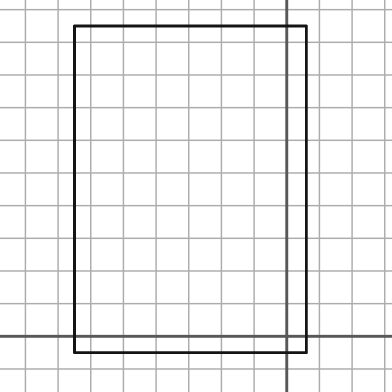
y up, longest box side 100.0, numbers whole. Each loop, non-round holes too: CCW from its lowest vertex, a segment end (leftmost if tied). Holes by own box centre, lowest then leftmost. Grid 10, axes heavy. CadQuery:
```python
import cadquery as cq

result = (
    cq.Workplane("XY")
    .moveTo(-65.0, -5.0)
    .lineTo(6.0, -5.0)
    .lineTo(6.0, 95.0)
    .lineTo(-65.0, 95.0)
    .close()
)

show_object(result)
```